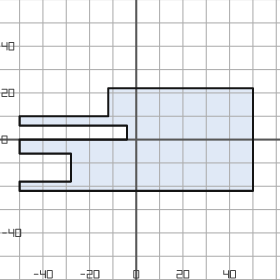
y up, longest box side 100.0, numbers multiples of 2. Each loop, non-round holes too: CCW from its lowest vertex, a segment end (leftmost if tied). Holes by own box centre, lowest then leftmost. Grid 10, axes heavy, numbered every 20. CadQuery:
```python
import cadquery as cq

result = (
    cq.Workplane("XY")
    .moveTo(-50.0, -22.0)
    .lineTo(50.0, -22.0)
    .lineTo(50.0, 22.0)
    .lineTo(-12.0, 22.0)
    .lineTo(-12.0, 10.0)
    .lineTo(-50.0, 10.0)
    .lineTo(-50.0, 6.0)
    .lineTo(-4.0, 6.0)
    .lineTo(-4.0, 0.0)
    .lineTo(-50.0, 0.0)
    .lineTo(-50.0, -6.0)
    .lineTo(-28.0, -6.0)
    .lineTo(-28.0, -18.0)
    .lineTo(-50.0, -18.0)
    .close()
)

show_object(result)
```